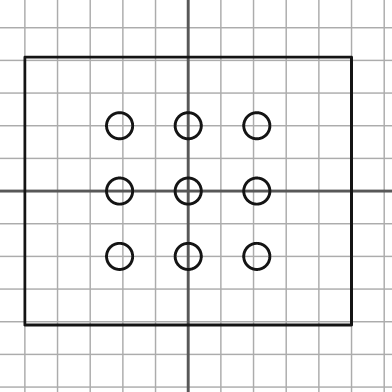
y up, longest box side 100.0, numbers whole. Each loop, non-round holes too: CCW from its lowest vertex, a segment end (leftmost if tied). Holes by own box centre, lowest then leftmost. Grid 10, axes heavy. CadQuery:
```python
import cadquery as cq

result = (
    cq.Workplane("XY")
    .moveTo(-50.0, -41.0)
    .lineTo(50.0, -41.0)
    .lineTo(50.0, 41.0)
    .lineTo(-50.0, 41.0)
    .close()
    .moveTo(-21.0, -20.0)
    .circle(4.0)
    .moveTo(0.0, -20.0)
    .circle(4.0)
    .moveTo(21.0, -20.0)
    .circle(4.0)
    .moveTo(-21.0, 0.0)
    .circle(4.0)
    .moveTo(0.0, 0.0)
    .circle(4.0)
    .moveTo(21.0, 0.0)
    .circle(4.0)
    .moveTo(-21.0, 20.0)
    .circle(4.0)
    .moveTo(0.0, 20.0)
    .circle(4.0)
    .moveTo(21.0, 20.0)
    .circle(4.0)
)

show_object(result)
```